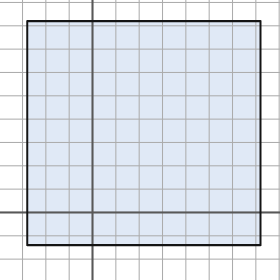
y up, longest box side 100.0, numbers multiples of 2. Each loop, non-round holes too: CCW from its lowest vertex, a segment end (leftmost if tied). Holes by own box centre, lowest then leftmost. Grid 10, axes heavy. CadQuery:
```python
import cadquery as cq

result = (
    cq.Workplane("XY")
    .moveTo(-28.0, -14.0)
    .lineTo(72.0, -14.0)
    .lineTo(72.0, 82.0)
    .lineTo(-28.0, 82.0)
    .close()
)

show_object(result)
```